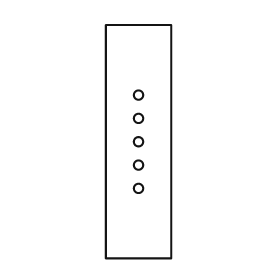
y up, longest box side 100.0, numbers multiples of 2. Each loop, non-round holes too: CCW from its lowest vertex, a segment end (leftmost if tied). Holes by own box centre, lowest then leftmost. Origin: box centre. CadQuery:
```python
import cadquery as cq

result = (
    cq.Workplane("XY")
    .moveTo(-14.0, -50.0)
    .lineTo(14.0, -50.0)
    .lineTo(14.0, 50.0)
    .lineTo(-14.0, 50.0)
    .close()
    .moveTo(0.0, -20.0)
    .circle(2.0)
    .moveTo(0.0, -10.0)
    .circle(2.0)
    .moveTo(0.0, 0.0)
    .circle(2.0)
    .moveTo(0.0, 10.0)
    .circle(2.0)
    .moveTo(0.0, 20.0)
    .circle(2.0)
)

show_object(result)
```